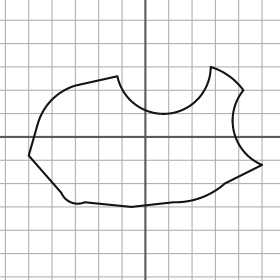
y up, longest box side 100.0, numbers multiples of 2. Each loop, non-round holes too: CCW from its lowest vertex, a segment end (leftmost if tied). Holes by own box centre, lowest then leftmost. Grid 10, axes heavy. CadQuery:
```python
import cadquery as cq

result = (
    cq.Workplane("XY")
    .moveTo(-6.0, -30.0)
    .lineTo(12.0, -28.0)
    .threePointArc((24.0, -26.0), (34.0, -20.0))
    .lineTo(50.0, -12.0)
    .threePointArc((38.0, 2.0), (42.0, 20.0))
    .threePointArc((36.0, 26.0), (28.0, 30.0))
    .threePointArc((10.0, 10.0), (-12.0, 26.0))
    .lineTo(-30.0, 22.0)
    .threePointArc((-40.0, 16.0), (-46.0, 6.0))
    .lineTo(-50.0, -8.0)
    .lineTo(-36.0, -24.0)
    .threePointArc((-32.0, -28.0), (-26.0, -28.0))
    .close()
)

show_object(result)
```